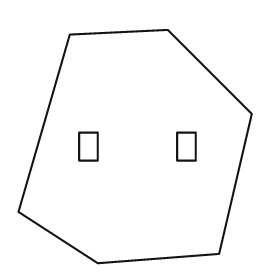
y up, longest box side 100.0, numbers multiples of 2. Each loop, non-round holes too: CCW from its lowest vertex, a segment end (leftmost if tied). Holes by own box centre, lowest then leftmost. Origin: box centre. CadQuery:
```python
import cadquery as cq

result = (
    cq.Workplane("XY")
    .moveTo(-16.0, -50.0)
    .lineTo(36.0, -46.0)
    .lineTo(50.0, 14.0)
    .lineTo(14.0, 50.0)
    .lineTo(-28.0, 48.0)
    .lineTo(-50.0, -28.0)
    .close()
    .moveTo(-24.0, -6.0)
    .lineTo(-16.0, -6.0)
    .lineTo(-16.0, 6.0)
    .lineTo(-24.0, 6.0)
    .close()
    .moveTo(18.0, -6.0)
    .lineTo(26.0, -6.0)
    .lineTo(26.0, 6.0)
    .lineTo(18.0, 6.0)
    .close()
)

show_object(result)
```